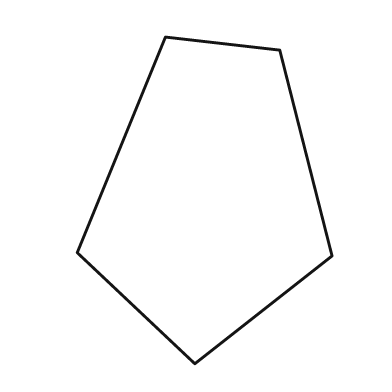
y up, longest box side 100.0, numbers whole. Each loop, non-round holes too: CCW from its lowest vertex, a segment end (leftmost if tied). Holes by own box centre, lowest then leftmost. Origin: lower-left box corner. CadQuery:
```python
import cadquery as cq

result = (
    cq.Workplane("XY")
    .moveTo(36.0, 0.0)
    .lineTo(78.0, 33.0)
    .lineTo(62.0, 96.0)
    .lineTo(27.0, 100.0)
    .lineTo(0.0, 34.0)
    .close()
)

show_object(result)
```